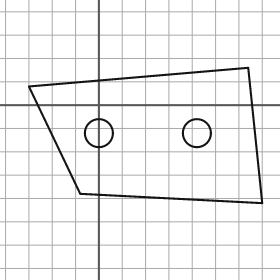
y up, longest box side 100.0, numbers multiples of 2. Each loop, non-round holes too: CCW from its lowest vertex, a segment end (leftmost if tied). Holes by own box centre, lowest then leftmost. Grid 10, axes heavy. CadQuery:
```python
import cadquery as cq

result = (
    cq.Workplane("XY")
    .moveTo(70.0, -42.0)
    .lineTo(64.0, 16.0)
    .lineTo(-30.0, 8.0)
    .lineTo(-8.0, -38.0)
    .close()
    .moveTo(0.0, -12.0)
    .circle(6.0)
    .moveTo(42.0, -12.0)
    .circle(6.0)
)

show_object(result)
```